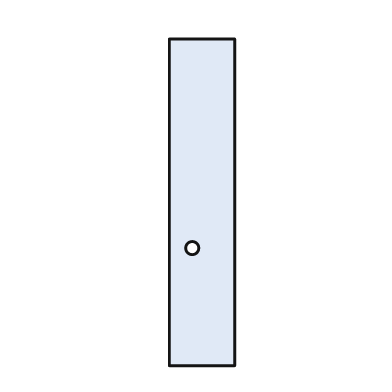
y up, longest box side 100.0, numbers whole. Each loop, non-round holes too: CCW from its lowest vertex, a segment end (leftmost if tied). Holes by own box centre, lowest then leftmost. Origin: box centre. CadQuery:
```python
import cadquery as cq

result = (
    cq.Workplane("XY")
    .moveTo(-10.0, -50.0)
    .lineTo(10.0, -50.0)
    .lineTo(10.0, 50.0)
    .lineTo(-10.0, 50.0)
    .close()
    .moveTo(-3.0, -14.0)
    .circle(2.0)
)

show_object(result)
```